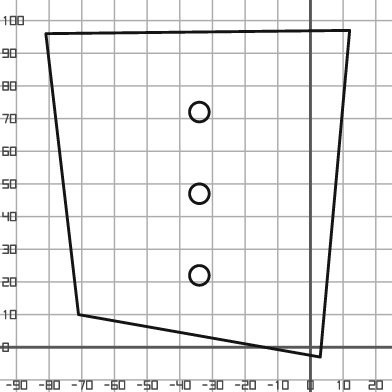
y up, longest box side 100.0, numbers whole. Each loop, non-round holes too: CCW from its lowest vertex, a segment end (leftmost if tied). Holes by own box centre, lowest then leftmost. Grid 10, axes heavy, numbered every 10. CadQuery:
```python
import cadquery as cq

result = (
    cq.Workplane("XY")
    .moveTo(3.0, -3.0)
    .lineTo(12.0, 97.0)
    .lineTo(-81.0, 96.0)
    .lineTo(-71.0, 10.0)
    .close()
    .moveTo(-34.0, 22.0)
    .circle(3.0)
    .moveTo(-34.0, 47.0)
    .circle(3.0)
    .moveTo(-34.0, 72.0)
    .circle(3.0)
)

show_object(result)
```